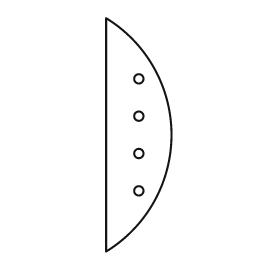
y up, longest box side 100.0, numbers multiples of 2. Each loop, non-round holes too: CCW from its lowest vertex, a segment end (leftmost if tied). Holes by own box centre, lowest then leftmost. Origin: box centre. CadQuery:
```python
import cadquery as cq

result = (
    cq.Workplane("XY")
    .moveTo(-14.0, -50.0)
    .threePointArc((14.0, 0.0), (-14.0, 50.0))
    .close()
    .moveTo(0.0, -24.0)
    .circle(2.0)
    .moveTo(0.0, -8.0)
    .circle(2.0)
    .moveTo(0.0, 8.0)
    .circle(2.0)
    .moveTo(0.0, 24.0)
    .circle(2.0)
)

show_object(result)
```